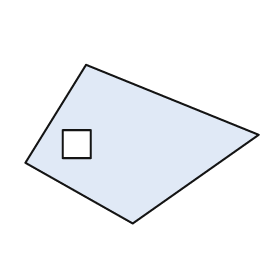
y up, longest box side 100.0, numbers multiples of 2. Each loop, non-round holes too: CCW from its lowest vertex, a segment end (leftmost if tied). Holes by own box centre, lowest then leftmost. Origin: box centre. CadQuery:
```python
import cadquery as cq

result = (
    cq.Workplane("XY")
    .moveTo(-4.0, -34.0)
    .lineTo(50.0, 4.0)
    .lineTo(-24.0, 34.0)
    .lineTo(-50.0, -8.0)
    .close()
    .moveTo(-34.0, -6.0)
    .lineTo(-22.0, -6.0)
    .lineTo(-22.0, 6.0)
    .lineTo(-34.0, 6.0)
    .close()
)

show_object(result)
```